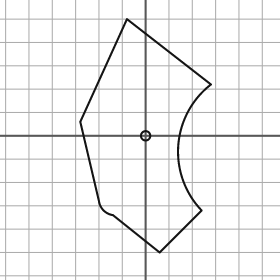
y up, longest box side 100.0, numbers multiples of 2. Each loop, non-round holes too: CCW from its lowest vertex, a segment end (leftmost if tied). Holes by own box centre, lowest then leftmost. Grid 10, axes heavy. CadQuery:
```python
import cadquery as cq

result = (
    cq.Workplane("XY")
    .moveTo(6.0, -50.0)
    .lineTo(24.0, -32.0)
    .threePointArc((14.0, -4.0), (28.0, 22.0))
    .lineTo(-8.0, 50.0)
    .lineTo(-28.0, 6.0)
    .lineTo(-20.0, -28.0)
    .threePointArc((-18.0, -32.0), (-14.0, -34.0))
    .close()
    .moveTo(0.0, 0.0)
    .circle(2.0)
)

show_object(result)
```